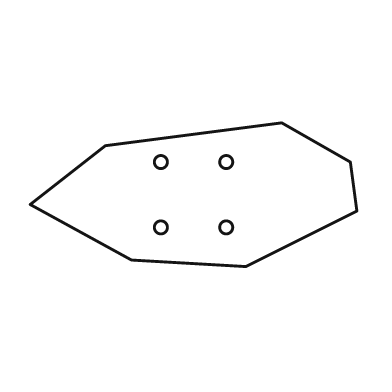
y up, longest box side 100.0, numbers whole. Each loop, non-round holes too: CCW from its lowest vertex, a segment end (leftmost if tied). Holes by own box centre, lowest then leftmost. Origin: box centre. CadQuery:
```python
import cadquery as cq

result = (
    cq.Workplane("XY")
    .moveTo(16.0, -22.0)
    .lineTo(50.0, -5.0)
    .lineTo(48.0, 10.0)
    .lineTo(27.0, 22.0)
    .lineTo(-27.0, 15.0)
    .lineTo(-50.0, -3.0)
    .lineTo(-19.0, -20.0)
    .close()
    .moveTo(-10.0, -10.0)
    .circle(2.0)
    .moveTo(10.0, -10.0)
    .circle(2.0)
    .moveTo(-10.0, 10.0)
    .circle(2.0)
    .moveTo(10.0, 10.0)
    .circle(2.0)
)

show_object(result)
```